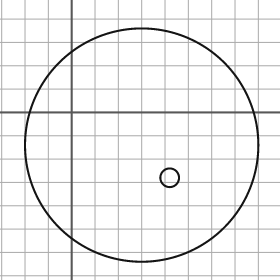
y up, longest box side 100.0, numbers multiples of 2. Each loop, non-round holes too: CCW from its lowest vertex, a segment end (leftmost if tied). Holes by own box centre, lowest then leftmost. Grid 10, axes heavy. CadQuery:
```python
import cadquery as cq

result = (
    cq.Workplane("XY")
    .moveTo(30.0, -14.0)
    .circle(50.0)
    .moveTo(42.0, -28.0)
    .circle(4.0)
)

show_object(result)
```